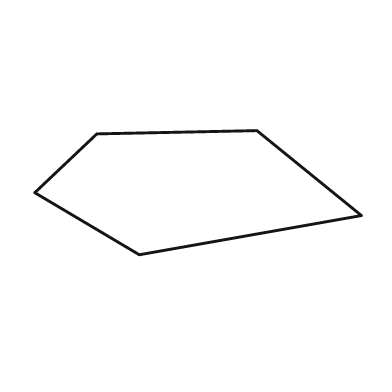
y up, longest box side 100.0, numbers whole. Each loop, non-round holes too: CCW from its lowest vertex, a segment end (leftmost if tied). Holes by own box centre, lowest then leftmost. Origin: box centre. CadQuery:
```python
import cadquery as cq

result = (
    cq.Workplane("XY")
    .moveTo(-18.0, -19.0)
    .lineTo(50.0, -7.0)
    .lineTo(18.0, 19.0)
    .lineTo(-31.0, 18.0)
    .lineTo(-50.0, 0.0)
    .close()
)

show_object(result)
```